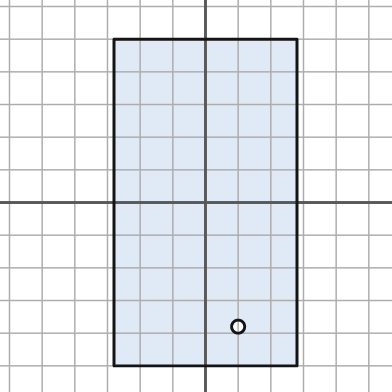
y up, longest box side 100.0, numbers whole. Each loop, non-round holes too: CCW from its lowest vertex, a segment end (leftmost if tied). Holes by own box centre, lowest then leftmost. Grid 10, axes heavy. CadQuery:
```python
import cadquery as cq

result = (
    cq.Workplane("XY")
    .moveTo(-28.0, -50.0)
    .lineTo(28.0, -50.0)
    .lineTo(28.0, 50.0)
    .lineTo(-28.0, 50.0)
    .close()
    .moveTo(10.0, -38.0)
    .circle(2.0)
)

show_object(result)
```